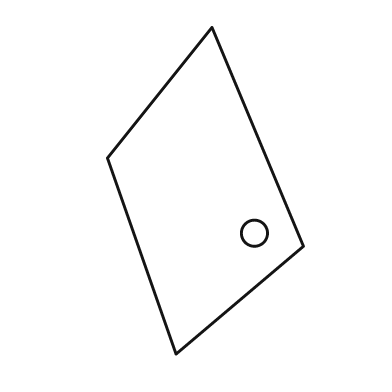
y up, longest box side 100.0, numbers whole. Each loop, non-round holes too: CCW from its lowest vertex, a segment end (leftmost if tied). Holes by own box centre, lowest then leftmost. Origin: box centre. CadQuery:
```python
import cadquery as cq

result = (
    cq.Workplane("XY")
    .moveTo(-9.0, -50.0)
    .lineTo(30.0, -17.0)
    .lineTo(2.0, 50.0)
    .lineTo(-30.0, 10.0)
    .close()
    .moveTo(15.0, -13.0)
    .circle(4.0)
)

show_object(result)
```